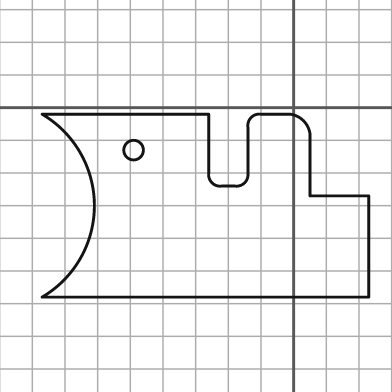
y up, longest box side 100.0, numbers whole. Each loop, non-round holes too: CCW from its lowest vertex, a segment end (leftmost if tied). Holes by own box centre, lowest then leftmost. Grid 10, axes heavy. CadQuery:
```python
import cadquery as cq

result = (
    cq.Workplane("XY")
    .moveTo(-77.0, -58.0)
    .lineTo(23.0, -58.0)
    .lineTo(23.0, -27.0)
    .lineTo(5.0, -27.0)
    .lineTo(5.0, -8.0)
    .threePointArc((3.0, -4.0), (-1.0, -2.0))
    .lineTo(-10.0, -2.0)
    .threePointArc((-13.0, -3.0), (-14.0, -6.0))
    .lineTo(-14.0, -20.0)
    .threePointArc((-15.0, -23.0), (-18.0, -24.0))
    .lineTo(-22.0, -24.0)
    .threePointArc((-25.0, -23.0), (-26.0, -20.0))
    .lineTo(-26.0, -2.0)
    .lineTo(-77.0, -2.0)
    .threePointArc((-61.0, -30.0), (-77.0, -58.0))
    .close()
    .moveTo(-49.0, -13.0)
    .circle(3.0)
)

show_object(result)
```